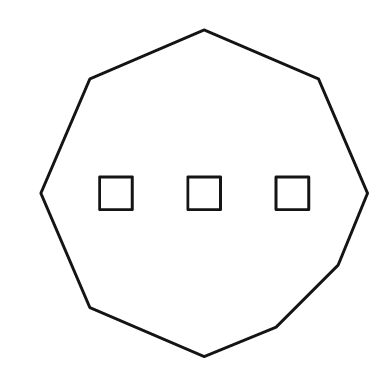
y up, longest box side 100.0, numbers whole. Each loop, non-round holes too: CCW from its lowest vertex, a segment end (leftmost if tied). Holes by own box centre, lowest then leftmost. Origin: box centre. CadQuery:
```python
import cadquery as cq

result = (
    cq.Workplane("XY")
    .moveTo(0.0, -50.0)
    .lineTo(22.0, -41.0)
    .lineTo(41.0, -22.0)
    .lineTo(50.0, 0.0)
    .lineTo(35.0, 35.0)
    .lineTo(0.0, 50.0)
    .lineTo(-35.0, 35.0)
    .lineTo(-50.0, 0.0)
    .lineTo(-35.0, -35.0)
    .close()
    .moveTo(-32.0, -5.0)
    .lineTo(-22.0, -5.0)
    .lineTo(-22.0, 5.0)
    .lineTo(-32.0, 5.0)
    .close()
    .moveTo(-5.0, -5.0)
    .lineTo(5.0, -5.0)
    .lineTo(5.0, 5.0)
    .lineTo(-5.0, 5.0)
    .close()
    .moveTo(22.0, -5.0)
    .lineTo(32.0, -5.0)
    .lineTo(32.0, 5.0)
    .lineTo(22.0, 5.0)
    .close()
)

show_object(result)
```